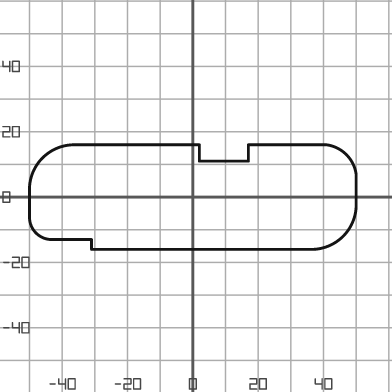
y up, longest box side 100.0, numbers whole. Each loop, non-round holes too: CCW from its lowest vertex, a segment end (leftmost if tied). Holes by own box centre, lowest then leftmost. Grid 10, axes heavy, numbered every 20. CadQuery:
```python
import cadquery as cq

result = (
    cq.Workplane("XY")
    .moveTo(-31.0, -16.0)
    .lineTo(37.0, -16.0)
    .threePointArc((46.0, -12.0), (50.0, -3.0))
    .lineTo(50.0, 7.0)
    .threePointArc((47.0, 13.0), (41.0, 16.0))
    .lineTo(17.0, 16.0)
    .lineTo(17.0, 11.0)
    .lineTo(2.0, 11.0)
    .lineTo(2.0, 16.0)
    .lineTo(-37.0, 16.0)
    .threePointArc((-46.0, 12.0), (-50.0, 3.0))
    .lineTo(-50.0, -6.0)
    .threePointArc((-48.0, -11.0), (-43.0, -13.0))
    .lineTo(-31.0, -13.0)
    .close()
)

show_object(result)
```